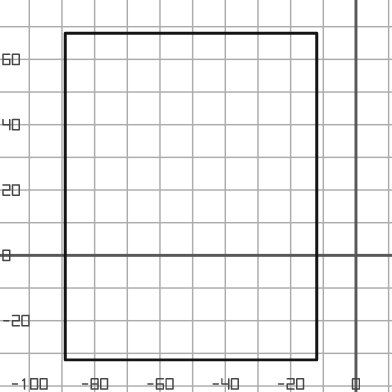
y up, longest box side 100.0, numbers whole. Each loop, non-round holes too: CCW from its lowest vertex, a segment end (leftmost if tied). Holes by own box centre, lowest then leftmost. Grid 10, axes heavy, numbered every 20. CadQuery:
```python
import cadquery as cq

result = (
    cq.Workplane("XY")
    .moveTo(-89.0, -32.0)
    .lineTo(-12.0, -32.0)
    .lineTo(-12.0, 68.0)
    .lineTo(-89.0, 68.0)
    .close()
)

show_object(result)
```